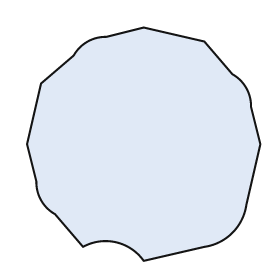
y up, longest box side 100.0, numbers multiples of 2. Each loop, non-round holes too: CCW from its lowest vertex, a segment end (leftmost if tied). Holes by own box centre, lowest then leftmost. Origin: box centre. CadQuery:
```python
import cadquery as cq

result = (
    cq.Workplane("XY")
    .moveTo(0.0, -50.0)
    .lineTo(26.0, -44.0)
    .threePointArc((38.0, -38.0), (44.0, -26.0))
    .lineTo(50.0, 0.0)
    .lineTo(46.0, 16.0)
    .threePointArc((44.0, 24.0), (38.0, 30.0))
    .lineTo(26.0, 44.0)
    .lineTo(0.0, 50.0)
    .lineTo(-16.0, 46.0)
    .threePointArc((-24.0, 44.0), (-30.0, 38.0))
    .lineTo(-44.0, 26.0)
    .lineTo(-50.0, 0.0)
    .lineTo(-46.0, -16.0)
    .threePointArc((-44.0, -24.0), (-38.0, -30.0))
    .lineTo(-26.0, -44.0)
    .threePointArc((-12.0, -42.0), (0.0, -50.0))
    .close()
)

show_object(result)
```